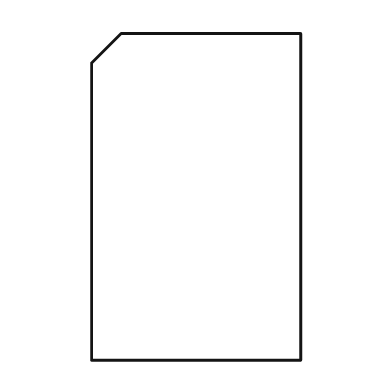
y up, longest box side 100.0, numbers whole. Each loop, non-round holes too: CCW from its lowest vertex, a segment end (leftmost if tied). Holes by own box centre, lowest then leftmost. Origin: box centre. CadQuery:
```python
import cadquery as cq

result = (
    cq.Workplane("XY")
    .moveTo(-32.0, -50.0)
    .lineTo(32.0, -50.0)
    .lineTo(32.0, 50.0)
    .lineTo(-23.0, 50.0)
    .lineTo(-32.0, 41.0)
    .close()
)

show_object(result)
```